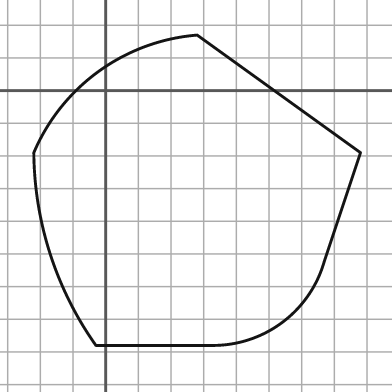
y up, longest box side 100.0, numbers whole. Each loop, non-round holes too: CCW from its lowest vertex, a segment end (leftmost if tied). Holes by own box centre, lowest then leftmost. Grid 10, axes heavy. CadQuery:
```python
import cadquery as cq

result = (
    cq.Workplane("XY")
    .moveTo(-3.0, -78.0)
    .lineTo(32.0, -78.0)
    .threePointArc((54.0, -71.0), (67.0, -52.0))
    .lineTo(78.0, -19.0)
    .lineTo(28.0, 17.0)
    .threePointArc((-2.0, 6.0), (-22.0, -19.0))
    .threePointArc((-17.0, -50.0), (-3.0, -78.0))
    .close()
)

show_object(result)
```